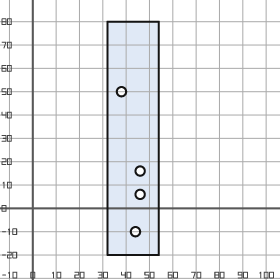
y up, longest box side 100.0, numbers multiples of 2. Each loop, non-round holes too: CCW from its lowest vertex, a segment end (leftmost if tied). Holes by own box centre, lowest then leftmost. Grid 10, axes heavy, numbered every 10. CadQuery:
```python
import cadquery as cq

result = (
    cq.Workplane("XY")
    .moveTo(32.0, -20.0)
    .lineTo(54.0, -20.0)
    .lineTo(54.0, 80.0)
    .lineTo(32.0, 80.0)
    .close()
    .moveTo(44.0, -10.0)
    .circle(2.0)
    .moveTo(46.0, 6.0)
    .circle(2.0)
    .moveTo(46.0, 16.0)
    .circle(2.0)
    .moveTo(38.0, 50.0)
    .circle(2.0)
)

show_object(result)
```